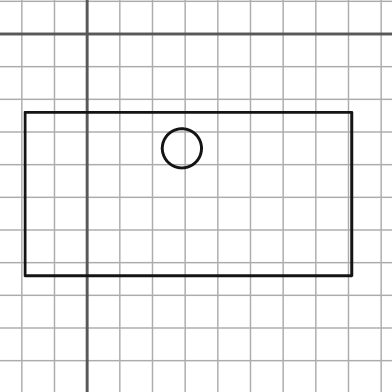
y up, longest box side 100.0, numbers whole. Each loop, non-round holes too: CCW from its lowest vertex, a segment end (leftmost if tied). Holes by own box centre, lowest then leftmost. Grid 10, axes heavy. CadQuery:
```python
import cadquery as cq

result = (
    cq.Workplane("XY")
    .moveTo(-19.0, -74.0)
    .lineTo(81.0, -74.0)
    .lineTo(81.0, -24.0)
    .lineTo(-19.0, -24.0)
    .close()
    .moveTo(29.0, -35.0)
    .circle(6.0)
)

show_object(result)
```